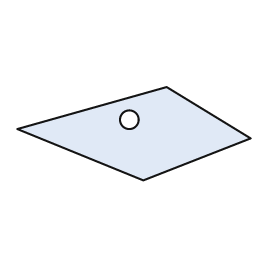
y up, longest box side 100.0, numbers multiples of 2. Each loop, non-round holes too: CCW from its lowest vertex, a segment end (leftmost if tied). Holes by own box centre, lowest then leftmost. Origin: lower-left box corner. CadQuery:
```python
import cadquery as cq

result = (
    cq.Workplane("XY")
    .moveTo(54.0, 0.0)
    .lineTo(100.0, 18.0)
    .lineTo(64.0, 40.0)
    .lineTo(0.0, 22.0)
    .close()
    .moveTo(48.0, 26.0)
    .circle(4.0)
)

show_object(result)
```